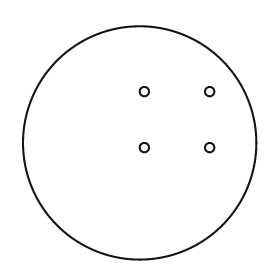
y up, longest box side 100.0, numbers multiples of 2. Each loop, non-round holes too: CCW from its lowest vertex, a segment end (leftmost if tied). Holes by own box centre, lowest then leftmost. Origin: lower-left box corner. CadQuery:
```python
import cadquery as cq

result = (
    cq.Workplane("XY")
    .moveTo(50.0, 50.0)
    .circle(50.0)
    .moveTo(52.0, 48.0)
    .circle(2.0)
    .moveTo(80.0, 48.0)
    .circle(2.0)
    .moveTo(52.0, 72.0)
    .circle(2.0)
    .moveTo(80.0, 72.0)
    .circle(2.0)
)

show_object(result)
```